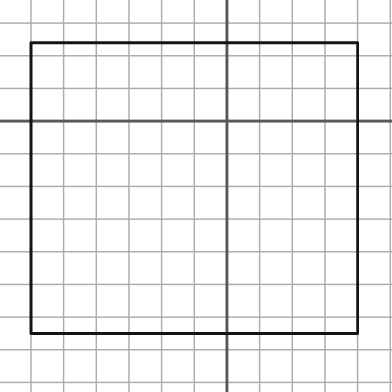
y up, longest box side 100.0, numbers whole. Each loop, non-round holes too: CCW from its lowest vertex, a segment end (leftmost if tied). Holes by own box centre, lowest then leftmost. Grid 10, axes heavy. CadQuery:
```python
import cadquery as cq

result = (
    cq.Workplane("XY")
    .moveTo(-60.0, -65.0)
    .lineTo(40.0, -65.0)
    .lineTo(40.0, 24.0)
    .lineTo(-60.0, 24.0)
    .close()
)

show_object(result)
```